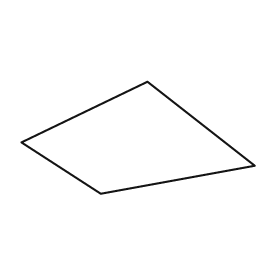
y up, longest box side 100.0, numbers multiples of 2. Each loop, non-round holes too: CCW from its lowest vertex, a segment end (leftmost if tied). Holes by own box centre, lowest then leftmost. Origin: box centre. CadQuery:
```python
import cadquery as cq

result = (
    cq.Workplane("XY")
    .moveTo(-16.0, -24.0)
    .lineTo(50.0, -12.0)
    .lineTo(4.0, 24.0)
    .lineTo(-50.0, -2.0)
    .close()
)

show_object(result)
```